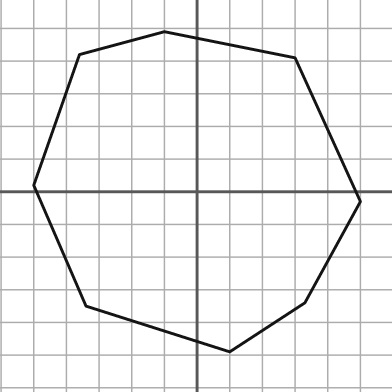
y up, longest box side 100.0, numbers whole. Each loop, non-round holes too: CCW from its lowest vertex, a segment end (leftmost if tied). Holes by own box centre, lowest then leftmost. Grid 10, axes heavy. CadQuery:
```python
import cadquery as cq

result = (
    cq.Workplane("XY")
    .moveTo(10.0, -49.0)
    .lineTo(33.0, -34.0)
    .lineTo(50.0, -3.0)
    .lineTo(30.0, 41.0)
    .lineTo(-10.0, 49.0)
    .lineTo(-36.0, 42.0)
    .lineTo(-50.0, 2.0)
    .lineTo(-34.0, -35.0)
    .close()
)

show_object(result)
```